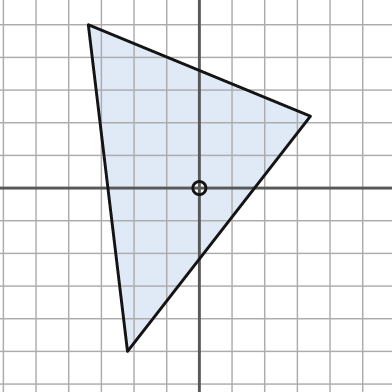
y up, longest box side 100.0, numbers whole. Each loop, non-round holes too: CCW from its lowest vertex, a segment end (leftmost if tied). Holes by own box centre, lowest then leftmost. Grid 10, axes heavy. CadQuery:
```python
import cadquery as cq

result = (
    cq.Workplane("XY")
    .moveTo(-22.0, -50.0)
    .lineTo(34.0, 22.0)
    .lineTo(-34.0, 50.0)
    .close()
    .moveTo(0.0, 0.0)
    .circle(2.0)
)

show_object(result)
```